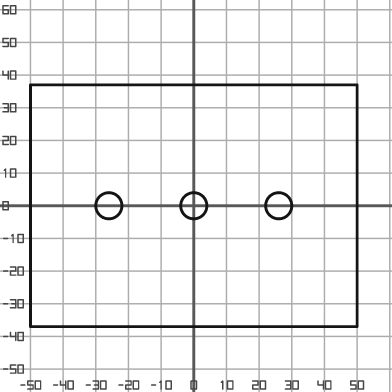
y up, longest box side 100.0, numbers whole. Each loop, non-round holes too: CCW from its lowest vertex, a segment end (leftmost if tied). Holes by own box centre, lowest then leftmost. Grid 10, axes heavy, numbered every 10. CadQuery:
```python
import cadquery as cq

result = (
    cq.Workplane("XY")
    .moveTo(-50.0, -37.0)
    .lineTo(50.0, -37.0)
    .lineTo(50.0, 37.0)
    .lineTo(-50.0, 37.0)
    .close()
    .moveTo(-26.0, 0.0)
    .circle(4.0)
    .moveTo(0.0, 0.0)
    .circle(4.0)
    .moveTo(26.0, 0.0)
    .circle(4.0)
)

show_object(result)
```